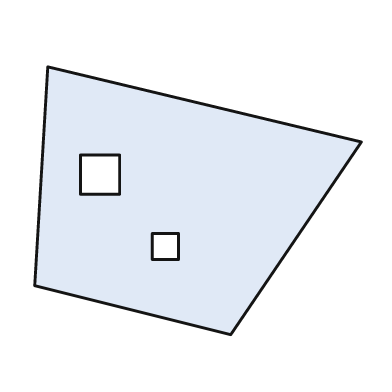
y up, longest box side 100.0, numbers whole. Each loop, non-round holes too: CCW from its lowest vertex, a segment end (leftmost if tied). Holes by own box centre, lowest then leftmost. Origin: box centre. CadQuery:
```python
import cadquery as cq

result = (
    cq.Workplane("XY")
    .moveTo(10.0, -41.0)
    .lineTo(50.0, 18.0)
    .lineTo(-46.0, 41.0)
    .lineTo(-50.0, -26.0)
    .close()
    .moveTo(-14.0, -18.0)
    .lineTo(-6.0, -18.0)
    .lineTo(-6.0, -10.0)
    .lineTo(-14.0, -10.0)
    .close()
    .moveTo(-36.0, 2.0)
    .lineTo(-24.0, 2.0)
    .lineTo(-24.0, 14.0)
    .lineTo(-36.0, 14.0)
    .close()
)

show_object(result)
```